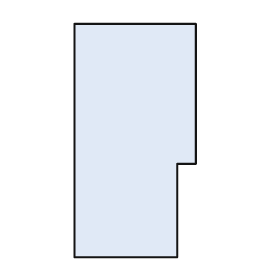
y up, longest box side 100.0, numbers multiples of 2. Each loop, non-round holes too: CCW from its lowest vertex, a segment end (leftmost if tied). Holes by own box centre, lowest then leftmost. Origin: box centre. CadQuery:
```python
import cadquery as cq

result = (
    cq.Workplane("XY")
    .moveTo(-26.0, -50.0)
    .lineTo(18.0, -50.0)
    .lineTo(18.0, -10.0)
    .lineTo(26.0, -10.0)
    .lineTo(26.0, 50.0)
    .lineTo(-26.0, 50.0)
    .close()
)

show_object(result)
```